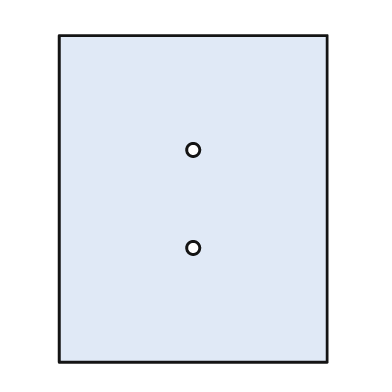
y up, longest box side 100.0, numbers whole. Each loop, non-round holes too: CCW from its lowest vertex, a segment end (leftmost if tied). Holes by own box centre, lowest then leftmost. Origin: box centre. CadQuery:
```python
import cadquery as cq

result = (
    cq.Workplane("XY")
    .moveTo(-41.0, -50.0)
    .lineTo(41.0, -50.0)
    .lineTo(41.0, 50.0)
    .lineTo(-41.0, 50.0)
    .close()
    .moveTo(0.0, -15.0)
    .circle(2.0)
    .moveTo(0.0, 15.0)
    .circle(2.0)
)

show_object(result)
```